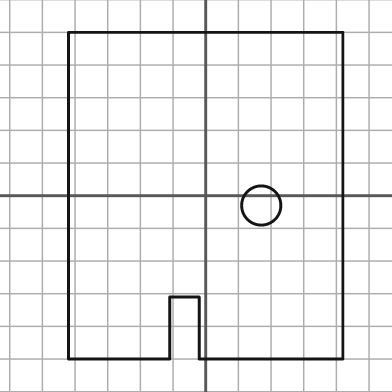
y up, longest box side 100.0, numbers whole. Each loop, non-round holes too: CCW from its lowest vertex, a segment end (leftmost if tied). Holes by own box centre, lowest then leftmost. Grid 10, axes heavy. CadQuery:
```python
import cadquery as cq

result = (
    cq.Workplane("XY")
    .moveTo(-42.0, -50.0)
    .lineTo(-11.0, -50.0)
    .lineTo(-11.0, -31.0)
    .lineTo(-2.0, -31.0)
    .lineTo(-2.0, -50.0)
    .lineTo(42.0, -50.0)
    .lineTo(42.0, 50.0)
    .lineTo(-42.0, 50.0)
    .close()
    .moveTo(17.0, -3.0)
    .circle(6.0)
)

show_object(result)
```